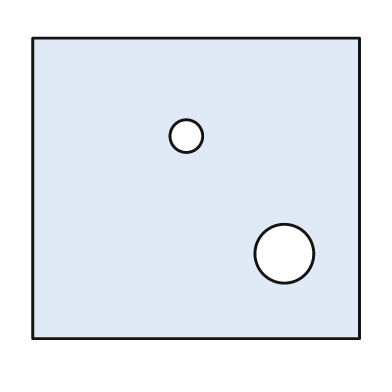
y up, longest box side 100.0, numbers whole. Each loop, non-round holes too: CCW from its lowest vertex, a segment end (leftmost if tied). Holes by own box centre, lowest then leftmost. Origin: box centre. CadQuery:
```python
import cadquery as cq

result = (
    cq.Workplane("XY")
    .moveTo(-50.0, -46.0)
    .lineTo(50.0, -46.0)
    .lineTo(50.0, 46.0)
    .lineTo(-50.0, 46.0)
    .close()
    .moveTo(27.0, -20.0)
    .circle(9.0)
    .moveTo(-3.0, 16.0)
    .circle(5.0)
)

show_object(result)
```